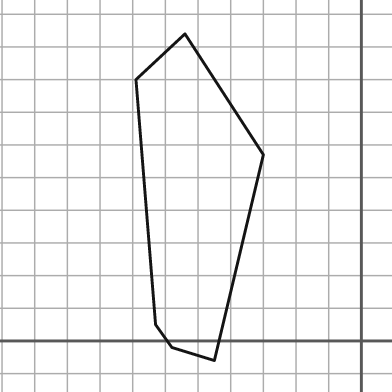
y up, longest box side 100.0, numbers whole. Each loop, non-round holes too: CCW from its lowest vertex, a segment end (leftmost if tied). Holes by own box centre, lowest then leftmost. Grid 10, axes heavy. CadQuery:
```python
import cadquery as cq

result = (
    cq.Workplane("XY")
    .moveTo(-45.0, -6.0)
    .lineTo(-30.0, 57.0)
    .lineTo(-54.0, 94.0)
    .lineTo(-69.0, 80.0)
    .lineTo(-63.0, 5.0)
    .lineTo(-58.0, -2.0)
    .close()
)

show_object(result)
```